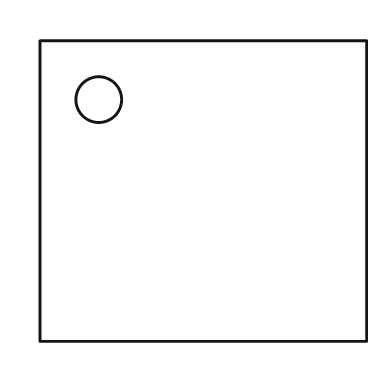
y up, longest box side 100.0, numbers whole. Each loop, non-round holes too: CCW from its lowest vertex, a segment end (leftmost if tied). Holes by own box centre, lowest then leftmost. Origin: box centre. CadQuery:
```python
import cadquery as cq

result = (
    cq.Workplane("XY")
    .moveTo(-50.0, -46.0)
    .lineTo(50.0, -46.0)
    .lineTo(50.0, 46.0)
    .lineTo(-50.0, 46.0)
    .close()
    .moveTo(-32.0, 28.0)
    .circle(7.0)
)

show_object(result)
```